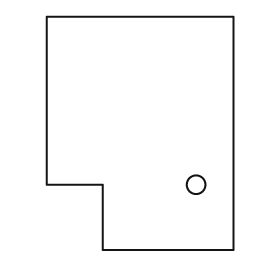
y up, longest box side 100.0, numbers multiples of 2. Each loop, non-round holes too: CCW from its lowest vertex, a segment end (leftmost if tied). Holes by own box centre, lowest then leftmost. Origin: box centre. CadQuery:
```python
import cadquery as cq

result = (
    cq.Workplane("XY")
    .moveTo(-16.0, -50.0)
    .lineTo(40.0, -50.0)
    .lineTo(40.0, 50.0)
    .lineTo(-40.0, 50.0)
    .lineTo(-40.0, -22.0)
    .lineTo(-16.0, -22.0)
    .close()
    .moveTo(24.0, -22.0)
    .circle(4.0)
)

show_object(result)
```